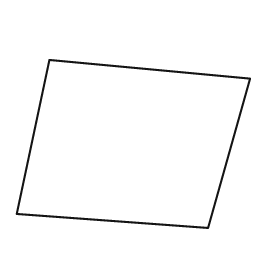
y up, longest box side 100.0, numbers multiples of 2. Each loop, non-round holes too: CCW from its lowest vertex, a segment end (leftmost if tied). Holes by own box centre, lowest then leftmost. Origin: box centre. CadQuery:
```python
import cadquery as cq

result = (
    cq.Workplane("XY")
    .moveTo(32.0, -36.0)
    .lineTo(50.0, 28.0)
    .lineTo(-36.0, 36.0)
    .lineTo(-50.0, -30.0)
    .close()
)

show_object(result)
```